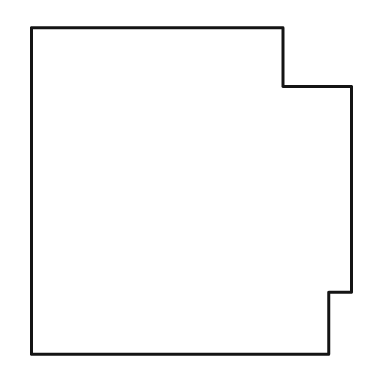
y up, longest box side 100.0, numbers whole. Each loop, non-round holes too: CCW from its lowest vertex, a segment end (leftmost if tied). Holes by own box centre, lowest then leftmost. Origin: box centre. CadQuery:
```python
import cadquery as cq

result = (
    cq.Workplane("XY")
    .moveTo(-49.0, -50.0)
    .lineTo(42.0, -50.0)
    .lineTo(42.0, -31.0)
    .lineTo(49.0, -31.0)
    .lineTo(49.0, 32.0)
    .lineTo(28.0, 32.0)
    .lineTo(28.0, 50.0)
    .lineTo(-49.0, 50.0)
    .close()
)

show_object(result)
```